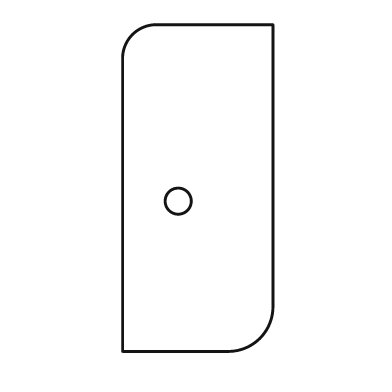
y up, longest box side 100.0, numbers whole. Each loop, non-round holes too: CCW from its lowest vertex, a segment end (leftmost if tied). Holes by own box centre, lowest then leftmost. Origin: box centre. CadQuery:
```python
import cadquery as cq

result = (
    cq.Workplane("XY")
    .moveTo(-23.0, -50.0)
    .lineTo(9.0, -50.0)
    .threePointArc((19.0, -46.0), (23.0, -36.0))
    .lineTo(23.0, 50.0)
    .lineTo(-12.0, 50.0)
    .threePointArc((-20.0, 47.0), (-23.0, 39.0))
    .close()
    .moveTo(-6.0, -4.0)
    .circle(4.0)
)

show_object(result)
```